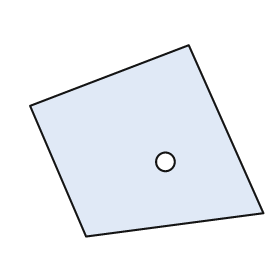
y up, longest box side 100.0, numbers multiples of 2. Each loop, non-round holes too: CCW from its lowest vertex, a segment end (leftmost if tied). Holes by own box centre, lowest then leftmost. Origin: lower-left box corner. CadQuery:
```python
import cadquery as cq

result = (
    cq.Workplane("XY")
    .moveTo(24.0, 0.0)
    .lineTo(100.0, 10.0)
    .lineTo(68.0, 82.0)
    .lineTo(0.0, 56.0)
    .close()
    .moveTo(58.0, 32.0)
    .circle(4.0)
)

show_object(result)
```